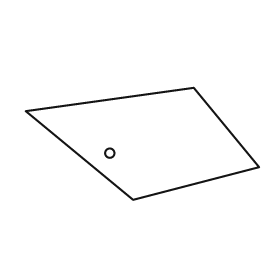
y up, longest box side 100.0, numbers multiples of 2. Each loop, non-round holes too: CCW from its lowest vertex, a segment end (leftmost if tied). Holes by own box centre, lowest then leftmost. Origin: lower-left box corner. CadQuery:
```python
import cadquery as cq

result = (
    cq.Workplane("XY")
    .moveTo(46.0, 0.0)
    .lineTo(100.0, 14.0)
    .lineTo(72.0, 48.0)
    .lineTo(0.0, 38.0)
    .close()
    .moveTo(36.0, 20.0)
    .circle(2.0)
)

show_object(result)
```